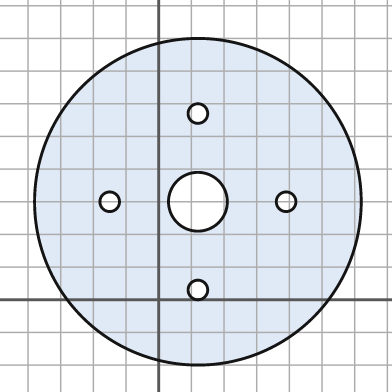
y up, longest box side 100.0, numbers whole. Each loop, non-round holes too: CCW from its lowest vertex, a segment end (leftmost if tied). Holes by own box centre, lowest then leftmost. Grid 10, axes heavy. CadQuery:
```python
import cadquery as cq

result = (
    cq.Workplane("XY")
    .moveTo(12.0, 30.0)
    .circle(50.0)
    .moveTo(12.0, 3.0)
    .circle(3.0)
    .moveTo(-15.0, 30.0)
    .circle(3.0)
    .moveTo(12.0, 30.0)
    .circle(9.0)
    .moveTo(39.0, 30.0)
    .circle(3.0)
    .moveTo(12.0, 57.0)
    .circle(3.0)
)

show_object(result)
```